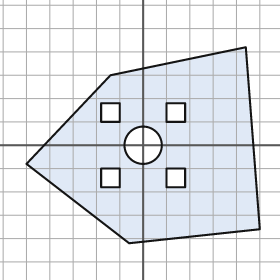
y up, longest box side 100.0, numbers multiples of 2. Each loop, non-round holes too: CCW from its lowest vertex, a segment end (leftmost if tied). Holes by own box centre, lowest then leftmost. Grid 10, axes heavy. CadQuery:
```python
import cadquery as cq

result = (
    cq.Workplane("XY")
    .moveTo(-6.0, -42.0)
    .lineTo(50.0, -36.0)
    .lineTo(44.0, 42.0)
    .lineTo(-14.0, 30.0)
    .lineTo(-50.0, -8.0)
    .close()
    .moveTo(-18.0, -18.0)
    .lineTo(-10.0, -18.0)
    .lineTo(-10.0, -10.0)
    .lineTo(-18.0, -10.0)
    .close()
    .moveTo(10.0, -18.0)
    .lineTo(18.0, -18.0)
    .lineTo(18.0, -10.0)
    .lineTo(10.0, -10.0)
    .close()
    .moveTo(0.0, 0.0)
    .circle(8.0)
    .moveTo(-18.0, 10.0)
    .lineTo(-10.0, 10.0)
    .lineTo(-10.0, 18.0)
    .lineTo(-18.0, 18.0)
    .close()
    .moveTo(10.0, 10.0)
    .lineTo(18.0, 10.0)
    .lineTo(18.0, 18.0)
    .lineTo(10.0, 18.0)
    .close()
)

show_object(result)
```